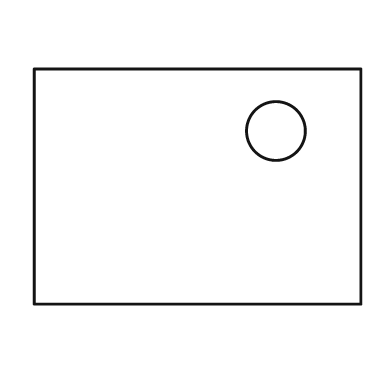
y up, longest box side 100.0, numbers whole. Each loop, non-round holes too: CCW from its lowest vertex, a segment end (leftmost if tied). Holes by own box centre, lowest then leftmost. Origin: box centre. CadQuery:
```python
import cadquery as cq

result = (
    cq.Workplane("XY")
    .moveTo(-50.0, -36.0)
    .lineTo(50.0, -36.0)
    .lineTo(50.0, 36.0)
    .lineTo(-50.0, 36.0)
    .close()
    .moveTo(24.0, 17.0)
    .circle(9.0)
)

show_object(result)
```